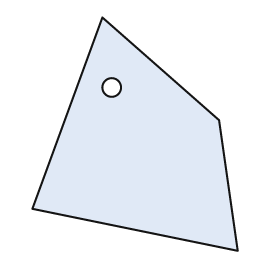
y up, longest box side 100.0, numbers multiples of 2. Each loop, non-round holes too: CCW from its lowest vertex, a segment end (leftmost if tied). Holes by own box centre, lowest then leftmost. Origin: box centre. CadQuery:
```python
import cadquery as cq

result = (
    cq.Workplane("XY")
    .moveTo(44.0, -50.0)
    .lineTo(36.0, 6.0)
    .lineTo(-14.0, 50.0)
    .lineTo(-44.0, -32.0)
    .close()
    .moveTo(-10.0, 20.0)
    .circle(4.0)
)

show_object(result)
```